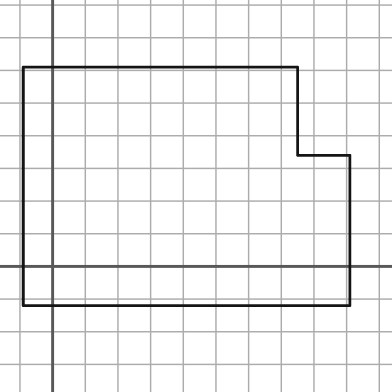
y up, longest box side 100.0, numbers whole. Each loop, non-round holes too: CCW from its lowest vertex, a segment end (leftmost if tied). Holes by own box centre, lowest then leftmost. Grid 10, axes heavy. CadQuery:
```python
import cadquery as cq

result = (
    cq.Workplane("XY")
    .moveTo(-9.0, -12.0)
    .lineTo(91.0, -12.0)
    .lineTo(91.0, 34.0)
    .lineTo(75.0, 34.0)
    .lineTo(75.0, 61.0)
    .lineTo(-9.0, 61.0)
    .close()
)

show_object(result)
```